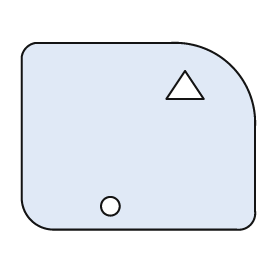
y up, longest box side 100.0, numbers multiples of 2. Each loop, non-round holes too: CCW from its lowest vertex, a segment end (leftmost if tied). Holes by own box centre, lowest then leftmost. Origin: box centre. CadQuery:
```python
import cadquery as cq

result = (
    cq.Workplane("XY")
    .moveTo(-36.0, -40.0)
    .lineTo(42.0, -40.0)
    .threePointArc((48.0, -38.0), (50.0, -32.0))
    .lineTo(50.0, 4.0)
    .threePointArc((40.0, 30.0), (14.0, 40.0))
    .lineTo(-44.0, 40.0)
    .threePointArc((-48.0, 38.0), (-50.0, 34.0))
    .lineTo(-50.0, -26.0)
    .threePointArc((-46.0, -36.0), (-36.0, -40.0))
    .close()
    .moveTo(-12.0, -30.0)
    .circle(4.0)
    .moveTo(12.0, 16.0)
    .lineTo(28.0, 16.0)
    .lineTo(20.0, 28.0)
    .close()
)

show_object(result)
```